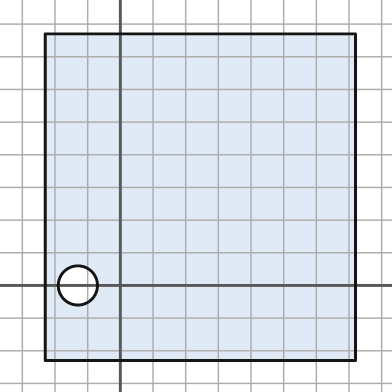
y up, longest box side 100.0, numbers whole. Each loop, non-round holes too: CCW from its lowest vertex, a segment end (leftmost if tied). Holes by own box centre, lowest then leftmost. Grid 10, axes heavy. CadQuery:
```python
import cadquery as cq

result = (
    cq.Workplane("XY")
    .moveTo(-23.0, -23.0)
    .lineTo(72.0, -23.0)
    .lineTo(72.0, 77.0)
    .lineTo(-23.0, 77.0)
    .close()
    .moveTo(-13.0, 0.0)
    .circle(6.0)
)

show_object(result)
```